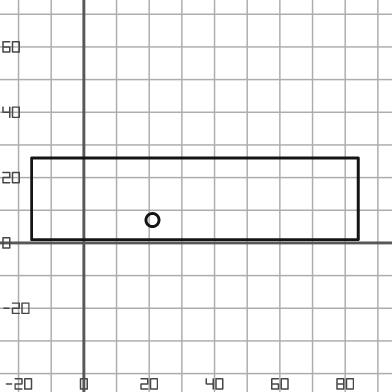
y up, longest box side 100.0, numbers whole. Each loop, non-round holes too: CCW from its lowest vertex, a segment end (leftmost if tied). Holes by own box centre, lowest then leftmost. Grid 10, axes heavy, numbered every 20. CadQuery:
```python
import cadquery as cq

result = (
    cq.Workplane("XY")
    .moveTo(-16.0, 1.0)
    .lineTo(84.0, 1.0)
    .lineTo(84.0, 26.0)
    .lineTo(-16.0, 26.0)
    .close()
    .moveTo(21.0, 7.0)
    .circle(2.0)
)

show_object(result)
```